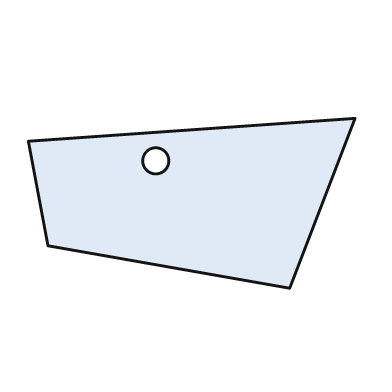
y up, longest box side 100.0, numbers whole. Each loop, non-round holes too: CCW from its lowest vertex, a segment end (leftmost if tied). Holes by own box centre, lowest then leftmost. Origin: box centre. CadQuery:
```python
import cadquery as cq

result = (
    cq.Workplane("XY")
    .moveTo(30.0, -26.0)
    .lineTo(50.0, 26.0)
    .lineTo(-50.0, 19.0)
    .lineTo(-44.0, -13.0)
    .close()
    .moveTo(-11.0, 13.0)
    .circle(4.0)
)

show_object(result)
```